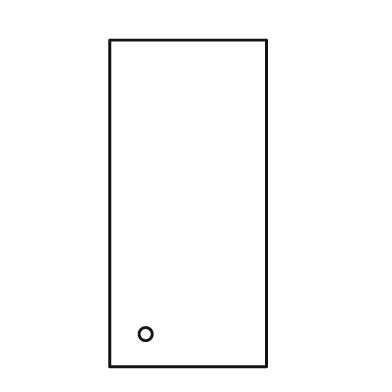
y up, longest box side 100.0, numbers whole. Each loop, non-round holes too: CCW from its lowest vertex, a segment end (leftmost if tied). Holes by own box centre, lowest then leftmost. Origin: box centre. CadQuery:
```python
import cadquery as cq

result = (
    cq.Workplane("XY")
    .moveTo(-24.0, -50.0)
    .lineTo(24.0, -50.0)
    .lineTo(24.0, 50.0)
    .lineTo(-24.0, 50.0)
    .close()
    .moveTo(-13.0, -40.0)
    .circle(2.0)
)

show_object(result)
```